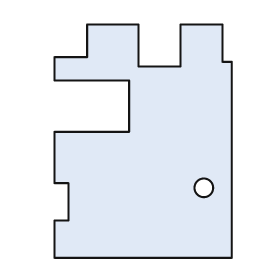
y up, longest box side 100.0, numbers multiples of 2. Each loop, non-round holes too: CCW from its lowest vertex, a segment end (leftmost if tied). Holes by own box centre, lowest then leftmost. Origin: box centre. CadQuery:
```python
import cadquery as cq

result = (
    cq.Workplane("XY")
    .moveTo(-38.0, -50.0)
    .lineTo(38.0, -50.0)
    .lineTo(38.0, 34.0)
    .lineTo(34.0, 34.0)
    .lineTo(34.0, 50.0)
    .lineTo(16.0, 50.0)
    .lineTo(16.0, 32.0)
    .lineTo(-2.0, 32.0)
    .lineTo(-2.0, 50.0)
    .lineTo(-24.0, 50.0)
    .lineTo(-24.0, 36.0)
    .lineTo(-38.0, 36.0)
    .lineTo(-38.0, 26.0)
    .lineTo(-6.0, 26.0)
    .lineTo(-6.0, 4.0)
    .lineTo(-38.0, 4.0)
    .lineTo(-38.0, -18.0)
    .lineTo(-32.0, -18.0)
    .lineTo(-32.0, -34.0)
    .lineTo(-38.0, -34.0)
    .close()
    .moveTo(26.0, -20.0)
    .circle(4.0)
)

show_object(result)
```